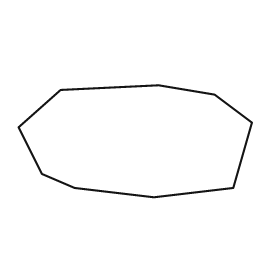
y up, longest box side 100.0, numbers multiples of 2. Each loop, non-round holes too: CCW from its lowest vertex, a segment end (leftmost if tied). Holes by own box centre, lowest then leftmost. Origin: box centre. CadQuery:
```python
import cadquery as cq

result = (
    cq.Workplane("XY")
    .moveTo(8.0, -24.0)
    .lineTo(42.0, -20.0)
    .lineTo(50.0, 8.0)
    .lineTo(34.0, 20.0)
    .lineTo(10.0, 24.0)
    .lineTo(-32.0, 22.0)
    .lineTo(-50.0, 6.0)
    .lineTo(-40.0, -14.0)
    .lineTo(-26.0, -20.0)
    .close()
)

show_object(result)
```